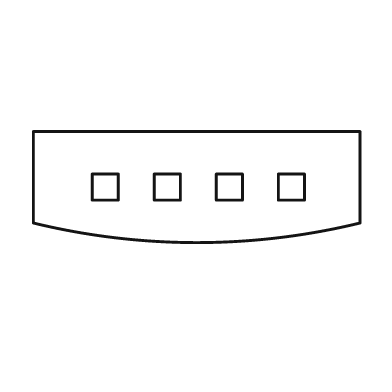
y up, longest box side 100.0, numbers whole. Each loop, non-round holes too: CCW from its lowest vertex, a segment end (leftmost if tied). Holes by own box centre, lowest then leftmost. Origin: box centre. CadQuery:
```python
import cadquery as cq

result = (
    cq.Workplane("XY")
    .moveTo(-50.0, -11.0)
    .threePointArc((0.0, -17.0), (50.0, -11.0))
    .lineTo(50.0, 17.0)
    .lineTo(-50.0, 17.0)
    .close()
    .moveTo(-32.0, -4.0)
    .lineTo(-24.0, -4.0)
    .lineTo(-24.0, 4.0)
    .lineTo(-32.0, 4.0)
    .close()
    .moveTo(-13.0, -4.0)
    .lineTo(-5.0, -4.0)
    .lineTo(-5.0, 4.0)
    .lineTo(-13.0, 4.0)
    .close()
    .moveTo(6.0, -4.0)
    .lineTo(14.0, -4.0)
    .lineTo(14.0, 4.0)
    .lineTo(6.0, 4.0)
    .close()
    .moveTo(25.0, -4.0)
    .lineTo(33.0, -4.0)
    .lineTo(33.0, 4.0)
    .lineTo(25.0, 4.0)
    .close()
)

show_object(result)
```